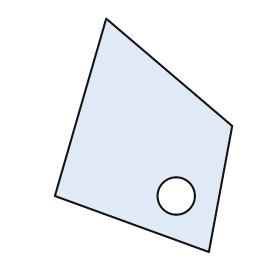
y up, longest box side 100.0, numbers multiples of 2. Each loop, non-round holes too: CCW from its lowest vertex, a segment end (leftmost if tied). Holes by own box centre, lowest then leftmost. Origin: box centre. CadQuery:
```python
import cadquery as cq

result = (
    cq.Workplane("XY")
    .moveTo(28.0, -50.0)
    .lineTo(38.0, 4.0)
    .lineTo(-16.0, 50.0)
    .lineTo(-38.0, -26.0)
    .close()
    .moveTo(14.0, -26.0)
    .circle(8.0)
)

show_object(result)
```